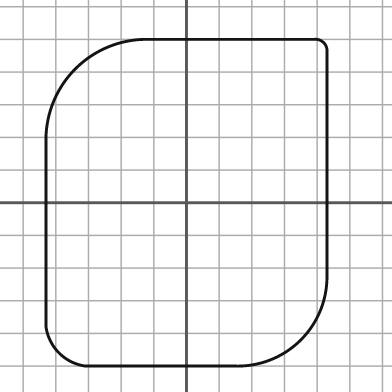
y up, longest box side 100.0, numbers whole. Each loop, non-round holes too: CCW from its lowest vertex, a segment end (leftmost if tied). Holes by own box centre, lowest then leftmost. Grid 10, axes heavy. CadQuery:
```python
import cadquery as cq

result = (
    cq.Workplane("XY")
    .moveTo(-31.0, -50.0)
    .lineTo(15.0, -50.0)
    .threePointArc((35.0, -42.0), (43.0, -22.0))
    .lineTo(43.0, 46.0)
    .threePointArc((42.0, 49.0), (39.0, 50.0))
    .lineTo(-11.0, 50.0)
    .threePointArc((-34.0, 41.0), (-43.0, 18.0))
    .lineTo(-43.0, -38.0)
    .threePointArc((-39.0, -46.0), (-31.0, -50.0))
    .close()
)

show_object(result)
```